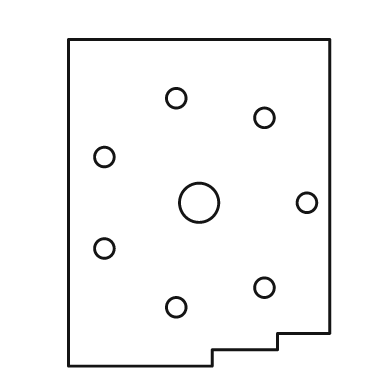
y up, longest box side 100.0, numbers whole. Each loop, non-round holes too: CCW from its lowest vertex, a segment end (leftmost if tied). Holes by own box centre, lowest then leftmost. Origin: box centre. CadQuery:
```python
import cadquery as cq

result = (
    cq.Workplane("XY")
    .moveTo(-40.0, -50.0)
    .lineTo(4.0, -50.0)
    .lineTo(4.0, -45.0)
    .lineTo(24.0, -45.0)
    .lineTo(24.0, -40.0)
    .lineTo(40.0, -40.0)
    .lineTo(40.0, 50.0)
    .lineTo(-40.0, 50.0)
    .close()
    .moveTo(-7.0, -32.0)
    .circle(3.0)
    .moveTo(20.0, -26.0)
    .circle(3.0)
    .moveTo(-29.0, -14.0)
    .circle(3.0)
    .moveTo(0.0, 0.0)
    .circle(6.0)
    .moveTo(33.0, 0.0)
    .circle(3.0)
    .moveTo(-29.0, 14.0)
    .circle(3.0)
    .moveTo(20.0, 26.0)
    .circle(3.0)
    .moveTo(-7.0, 32.0)
    .circle(3.0)
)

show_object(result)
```